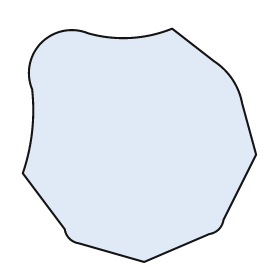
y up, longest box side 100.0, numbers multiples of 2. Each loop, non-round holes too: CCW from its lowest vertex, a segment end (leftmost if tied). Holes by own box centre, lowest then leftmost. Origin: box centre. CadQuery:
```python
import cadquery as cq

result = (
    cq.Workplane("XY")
    .moveTo(2.0, -50.0)
    .lineTo(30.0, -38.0)
    .threePointArc((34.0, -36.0), (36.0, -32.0))
    .lineTo(50.0, -4.0)
    .lineTo(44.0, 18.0)
    .threePointArc((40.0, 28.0), (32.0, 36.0))
    .lineTo(14.0, 50.0)
    .threePointArc((-4.0, 46.0), (-22.0, 48.0))
    .threePointArc((-42.0, 44.0), (-46.0, 24.0))
    .threePointArc((-46.0, 6.0), (-50.0, -12.0))
    .lineTo(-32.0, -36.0)
    .threePointArc((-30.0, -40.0), (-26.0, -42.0))
    .close()
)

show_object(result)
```